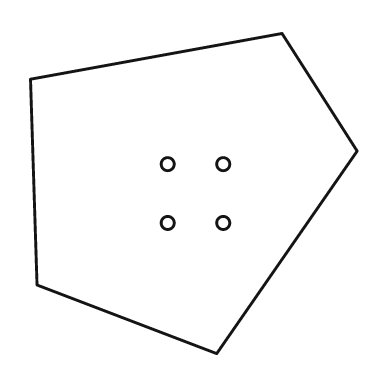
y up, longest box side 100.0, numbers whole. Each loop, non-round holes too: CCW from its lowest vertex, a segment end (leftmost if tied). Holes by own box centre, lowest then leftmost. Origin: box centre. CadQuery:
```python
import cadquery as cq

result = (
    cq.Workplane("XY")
    .moveTo(7.0, -49.0)
    .lineTo(50.0, 13.0)
    .lineTo(27.0, 49.0)
    .lineTo(-50.0, 35.0)
    .lineTo(-48.0, -28.0)
    .close()
    .moveTo(-8.0, -9.0)
    .circle(2.0)
    .moveTo(9.0, -9.0)
    .circle(2.0)
    .moveTo(-8.0, 9.0)
    .circle(2.0)
    .moveTo(9.0, 9.0)
    .circle(2.0)
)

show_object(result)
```